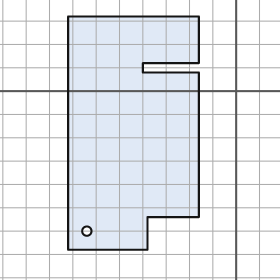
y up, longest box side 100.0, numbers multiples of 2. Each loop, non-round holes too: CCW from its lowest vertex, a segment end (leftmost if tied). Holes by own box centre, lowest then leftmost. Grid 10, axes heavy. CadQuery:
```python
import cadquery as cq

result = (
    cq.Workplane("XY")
    .moveTo(-72.0, -68.0)
    .lineTo(-38.0, -68.0)
    .lineTo(-38.0, -54.0)
    .lineTo(-16.0, -54.0)
    .lineTo(-16.0, 8.0)
    .lineTo(-40.0, 8.0)
    .lineTo(-40.0, 12.0)
    .lineTo(-16.0, 12.0)
    .lineTo(-16.0, 32.0)
    .lineTo(-72.0, 32.0)
    .close()
    .moveTo(-64.0, -60.0)
    .circle(2.0)
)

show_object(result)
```